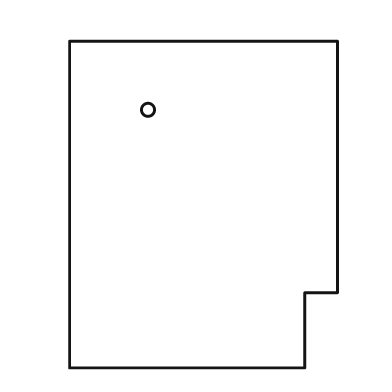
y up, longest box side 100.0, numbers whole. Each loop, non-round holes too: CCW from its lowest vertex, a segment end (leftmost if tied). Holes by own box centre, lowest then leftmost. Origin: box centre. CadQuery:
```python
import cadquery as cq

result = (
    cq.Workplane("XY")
    .moveTo(-41.0, -50.0)
    .lineTo(31.0, -50.0)
    .lineTo(31.0, -27.0)
    .lineTo(41.0, -27.0)
    .lineTo(41.0, 50.0)
    .lineTo(-41.0, 50.0)
    .close()
    .moveTo(-17.0, 29.0)
    .circle(2.0)
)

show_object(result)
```